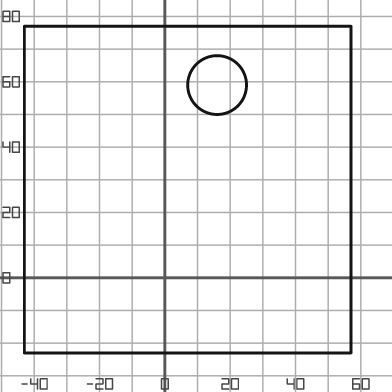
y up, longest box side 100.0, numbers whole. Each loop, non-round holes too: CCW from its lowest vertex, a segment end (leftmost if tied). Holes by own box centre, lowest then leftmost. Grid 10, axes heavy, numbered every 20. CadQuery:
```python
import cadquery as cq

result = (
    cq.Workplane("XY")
    .moveTo(-43.0, -23.0)
    .lineTo(57.0, -23.0)
    .lineTo(57.0, 77.0)
    .lineTo(-43.0, 77.0)
    .close()
    .moveTo(16.0, 59.0)
    .circle(9.0)
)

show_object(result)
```